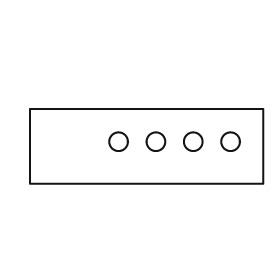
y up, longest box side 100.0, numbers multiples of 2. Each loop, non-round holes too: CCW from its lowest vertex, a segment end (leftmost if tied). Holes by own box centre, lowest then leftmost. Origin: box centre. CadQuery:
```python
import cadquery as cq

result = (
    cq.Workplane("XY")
    .moveTo(-50.0, -16.0)
    .lineTo(50.0, -16.0)
    .lineTo(50.0, 16.0)
    .lineTo(-50.0, 16.0)
    .close()
    .moveTo(-12.0, 2.0)
    .circle(4.0)
    .moveTo(4.0, 2.0)
    .circle(4.0)
    .moveTo(20.0, 2.0)
    .circle(4.0)
    .moveTo(36.0, 2.0)
    .circle(4.0)
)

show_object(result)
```